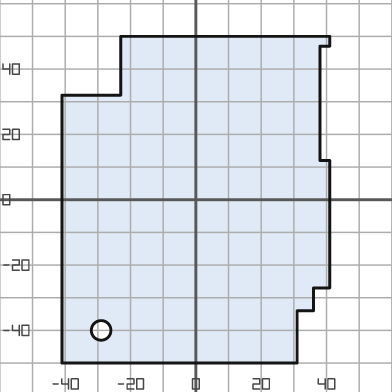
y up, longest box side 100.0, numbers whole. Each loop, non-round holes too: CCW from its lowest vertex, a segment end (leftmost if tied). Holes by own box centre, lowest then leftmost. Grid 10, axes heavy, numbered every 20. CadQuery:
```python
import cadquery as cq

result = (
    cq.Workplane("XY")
    .moveTo(-41.0, -50.0)
    .lineTo(31.0, -50.0)
    .lineTo(31.0, -34.0)
    .lineTo(36.0, -34.0)
    .lineTo(36.0, -27.0)
    .lineTo(41.0, -27.0)
    .lineTo(41.0, 12.0)
    .lineTo(38.0, 12.0)
    .lineTo(38.0, 47.0)
    .lineTo(41.0, 47.0)
    .lineTo(41.0, 50.0)
    .lineTo(-23.0, 50.0)
    .lineTo(-23.0, 32.0)
    .lineTo(-41.0, 32.0)
    .close()
    .moveTo(-29.0, -40.0)
    .circle(3.0)
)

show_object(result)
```